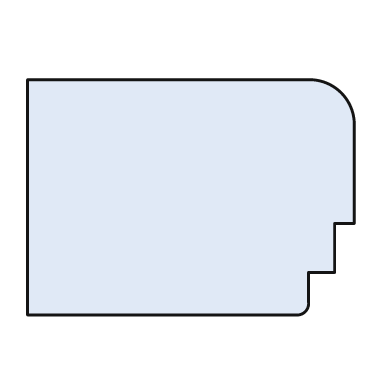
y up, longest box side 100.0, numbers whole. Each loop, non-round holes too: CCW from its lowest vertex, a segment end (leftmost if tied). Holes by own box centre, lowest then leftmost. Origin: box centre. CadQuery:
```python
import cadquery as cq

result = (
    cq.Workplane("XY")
    .moveTo(-50.0, -36.0)
    .lineTo(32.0, -36.0)
    .threePointArc((35.0, -35.0), (36.0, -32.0))
    .lineTo(36.0, -23.0)
    .lineTo(44.0, -23.0)
    .lineTo(44.0, -8.0)
    .lineTo(50.0, -8.0)
    .lineTo(50.0, 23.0)
    .threePointArc((46.0, 32.0), (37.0, 36.0))
    .lineTo(-50.0, 36.0)
    .close()
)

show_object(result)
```